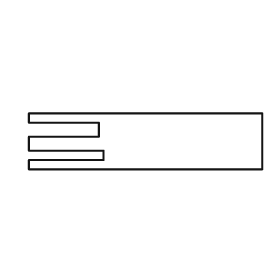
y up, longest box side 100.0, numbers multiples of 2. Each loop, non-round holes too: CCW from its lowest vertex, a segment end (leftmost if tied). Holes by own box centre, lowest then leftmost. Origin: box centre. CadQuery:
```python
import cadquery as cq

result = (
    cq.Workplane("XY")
    .moveTo(-50.0, -12.0)
    .lineTo(50.0, -12.0)
    .lineTo(50.0, 12.0)
    .lineTo(-50.0, 12.0)
    .lineTo(-50.0, 8.0)
    .lineTo(-20.0, 8.0)
    .lineTo(-20.0, 2.0)
    .lineTo(-50.0, 2.0)
    .lineTo(-50.0, -4.0)
    .lineTo(-18.0, -4.0)
    .lineTo(-18.0, -8.0)
    .lineTo(-50.0, -8.0)
    .close()
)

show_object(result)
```